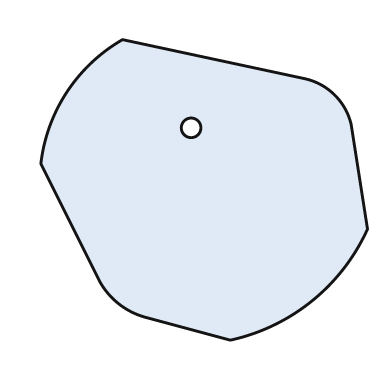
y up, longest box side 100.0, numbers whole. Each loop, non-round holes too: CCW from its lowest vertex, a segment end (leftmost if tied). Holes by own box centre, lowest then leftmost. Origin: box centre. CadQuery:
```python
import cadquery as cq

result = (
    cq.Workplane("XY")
    .moveTo(8.0, -46.0)
    .threePointArc((33.0, -34.0), (50.0, -12.0))
    .lineTo(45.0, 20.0)
    .threePointArc((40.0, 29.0), (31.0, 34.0))
    .lineTo(-25.0, 46.0)
    .threePointArc((-42.0, 30.0), (-50.0, 8.0))
    .lineTo(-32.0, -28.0)
    .threePointArc((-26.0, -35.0), (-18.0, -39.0))
    .close()
    .moveTo(-4.0, 19.0)
    .circle(3.0)
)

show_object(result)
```